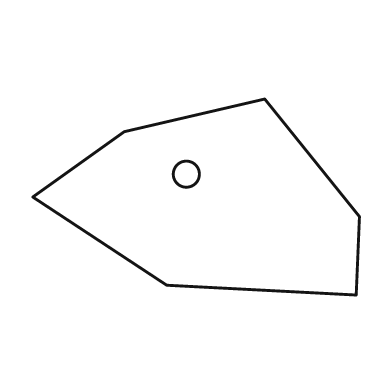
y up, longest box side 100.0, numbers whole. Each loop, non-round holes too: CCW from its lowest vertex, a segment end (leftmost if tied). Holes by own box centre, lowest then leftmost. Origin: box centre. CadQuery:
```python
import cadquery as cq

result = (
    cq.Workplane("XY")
    .moveTo(49.0, -30.0)
    .lineTo(50.0, -6.0)
    .lineTo(21.0, 30.0)
    .lineTo(-22.0, 20.0)
    .lineTo(-50.0, 0.0)
    .lineTo(-9.0, -27.0)
    .close()
    .moveTo(-3.0, 7.0)
    .circle(4.0)
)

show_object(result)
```